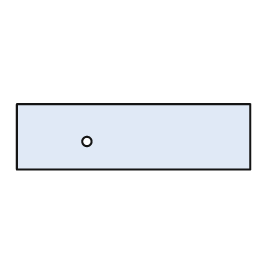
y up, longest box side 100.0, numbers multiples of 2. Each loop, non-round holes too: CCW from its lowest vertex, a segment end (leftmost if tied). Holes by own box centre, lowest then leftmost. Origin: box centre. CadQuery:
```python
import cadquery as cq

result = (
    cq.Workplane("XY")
    .moveTo(-50.0, -14.0)
    .lineTo(50.0, -14.0)
    .lineTo(50.0, 14.0)
    .lineTo(-50.0, 14.0)
    .close()
    .moveTo(-20.0, -2.0)
    .circle(2.0)
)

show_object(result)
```